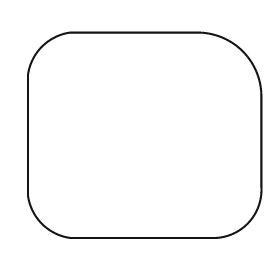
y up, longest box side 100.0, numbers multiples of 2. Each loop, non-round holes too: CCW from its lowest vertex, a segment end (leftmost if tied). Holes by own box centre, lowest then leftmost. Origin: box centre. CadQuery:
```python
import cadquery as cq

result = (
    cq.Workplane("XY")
    .moveTo(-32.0, -44.0)
    .lineTo(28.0, -44.0)
    .threePointArc((44.0, -38.0), (50.0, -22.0))
    .lineTo(50.0, 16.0)
    .threePointArc((42.0, 36.0), (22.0, 44.0))
    .lineTo(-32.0, 44.0)
    .threePointArc((-44.0, 38.0), (-50.0, 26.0))
    .lineTo(-50.0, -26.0)
    .threePointArc((-44.0, -38.0), (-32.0, -44.0))
    .close()
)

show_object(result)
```